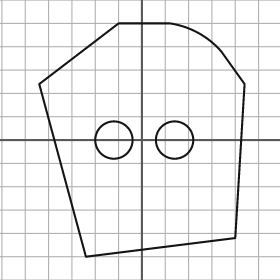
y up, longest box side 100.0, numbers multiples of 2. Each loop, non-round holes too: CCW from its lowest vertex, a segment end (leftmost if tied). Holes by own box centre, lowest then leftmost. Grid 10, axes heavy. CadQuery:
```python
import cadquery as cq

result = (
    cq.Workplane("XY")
    .moveTo(-24.0, -50.0)
    .lineTo(40.0, -42.0)
    .lineTo(44.0, 24.0)
    .lineTo(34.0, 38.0)
    .threePointArc((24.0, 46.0), (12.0, 50.0))
    .lineTo(-10.0, 50.0)
    .lineTo(-44.0, 24.0)
    .close()
    .moveTo(-12.0, 0.0)
    .circle(8.0)
    .moveTo(14.0, 0.0)
    .circle(8.0)
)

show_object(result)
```